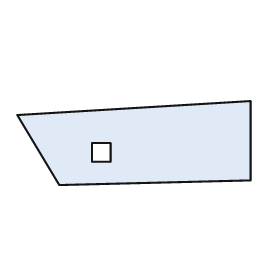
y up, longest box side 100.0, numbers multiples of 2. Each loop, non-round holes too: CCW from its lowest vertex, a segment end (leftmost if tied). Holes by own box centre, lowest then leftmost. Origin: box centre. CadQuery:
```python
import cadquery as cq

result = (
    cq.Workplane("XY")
    .moveTo(-32.0, -18.0)
    .lineTo(50.0, -16.0)
    .lineTo(50.0, 18.0)
    .lineTo(-50.0, 12.0)
    .close()
    .moveTo(-18.0, -8.0)
    .lineTo(-10.0, -8.0)
    .lineTo(-10.0, 0.0)
    .lineTo(-18.0, 0.0)
    .close()
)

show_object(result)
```